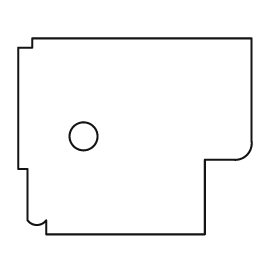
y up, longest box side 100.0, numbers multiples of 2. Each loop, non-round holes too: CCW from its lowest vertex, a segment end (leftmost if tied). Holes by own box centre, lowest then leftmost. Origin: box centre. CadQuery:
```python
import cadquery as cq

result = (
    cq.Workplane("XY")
    .moveTo(-38.0, -42.0)
    .lineTo(30.0, -42.0)
    .lineTo(30.0, -10.0)
    .lineTo(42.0, -10.0)
    .threePointArc((48.0, -8.0), (50.0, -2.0))
    .lineTo(50.0, 42.0)
    .lineTo(-44.0, 42.0)
    .lineTo(-44.0, 38.0)
    .lineTo(-50.0, 38.0)
    .lineTo(-50.0, -14.0)
    .lineTo(-46.0, -14.0)
    .lineTo(-46.0, -36.0)
    .threePointArc((-42.0, -38.0), (-38.0, -36.0))
    .close()
    .moveTo(-22.0, 0.0)
    .circle(6.0)
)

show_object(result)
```